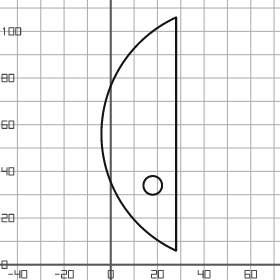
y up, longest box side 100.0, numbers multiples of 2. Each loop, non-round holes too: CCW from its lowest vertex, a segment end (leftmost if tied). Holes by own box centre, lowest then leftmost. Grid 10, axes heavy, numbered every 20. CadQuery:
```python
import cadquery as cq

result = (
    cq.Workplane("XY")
    .moveTo(28.0, 6.0)
    .lineTo(28.0, 106.0)
    .threePointArc((-4.0, 56.0), (28.0, 6.0))
    .close()
    .moveTo(18.0, 34.0)
    .circle(4.0)
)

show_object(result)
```